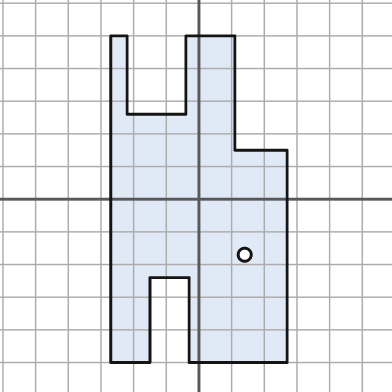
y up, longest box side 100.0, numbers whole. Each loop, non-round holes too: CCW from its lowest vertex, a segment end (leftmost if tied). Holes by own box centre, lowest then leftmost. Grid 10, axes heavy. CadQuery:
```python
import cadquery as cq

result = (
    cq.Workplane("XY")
    .moveTo(-27.0, -50.0)
    .lineTo(-15.0, -50.0)
    .lineTo(-15.0, -24.0)
    .lineTo(-3.0, -24.0)
    .lineTo(-3.0, -50.0)
    .lineTo(27.0, -50.0)
    .lineTo(27.0, 15.0)
    .lineTo(11.0, 15.0)
    .lineTo(11.0, 50.0)
    .lineTo(-4.0, 50.0)
    .lineTo(-4.0, 26.0)
    .lineTo(-22.0, 26.0)
    .lineTo(-22.0, 50.0)
    .lineTo(-27.0, 50.0)
    .close()
    .moveTo(14.0, -17.0)
    .circle(2.0)
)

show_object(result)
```